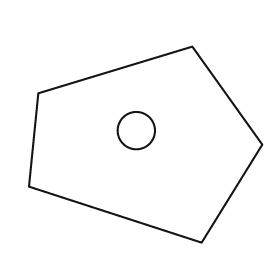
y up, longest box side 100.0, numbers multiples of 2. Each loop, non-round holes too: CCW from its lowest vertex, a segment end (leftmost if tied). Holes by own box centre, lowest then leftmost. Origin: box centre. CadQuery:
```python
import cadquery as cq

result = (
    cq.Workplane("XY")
    .moveTo(24.0, -42.0)
    .lineTo(50.0, 0.0)
    .lineTo(20.0, 42.0)
    .lineTo(-46.0, 22.0)
    .lineTo(-50.0, -18.0)
    .close()
    .moveTo(-4.0, 6.0)
    .circle(8.0)
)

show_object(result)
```